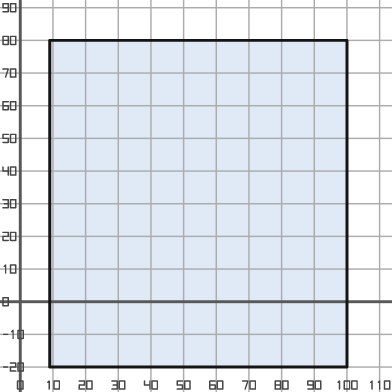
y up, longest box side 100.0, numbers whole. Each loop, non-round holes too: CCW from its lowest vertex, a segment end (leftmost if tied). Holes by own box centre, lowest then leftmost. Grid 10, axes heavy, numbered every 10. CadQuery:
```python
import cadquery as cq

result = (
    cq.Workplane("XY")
    .moveTo(9.0, -20.0)
    .lineTo(100.0, -20.0)
    .lineTo(100.0, 80.0)
    .lineTo(9.0, 80.0)
    .close()
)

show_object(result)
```